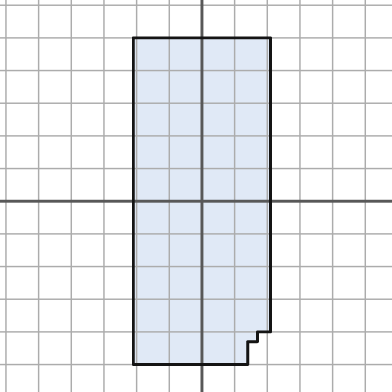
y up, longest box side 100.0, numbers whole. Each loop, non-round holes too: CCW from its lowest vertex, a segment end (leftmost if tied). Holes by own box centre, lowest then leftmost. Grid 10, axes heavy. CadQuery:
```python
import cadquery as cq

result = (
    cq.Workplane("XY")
    .moveTo(-21.0, -50.0)
    .lineTo(14.0, -50.0)
    .lineTo(14.0, -43.0)
    .lineTo(17.0, -43.0)
    .lineTo(17.0, -40.0)
    .lineTo(21.0, -40.0)
    .lineTo(21.0, 50.0)
    .lineTo(-21.0, 50.0)
    .close()
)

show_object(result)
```